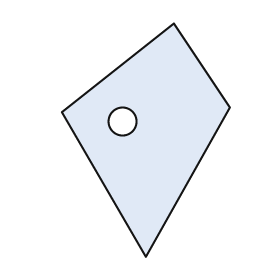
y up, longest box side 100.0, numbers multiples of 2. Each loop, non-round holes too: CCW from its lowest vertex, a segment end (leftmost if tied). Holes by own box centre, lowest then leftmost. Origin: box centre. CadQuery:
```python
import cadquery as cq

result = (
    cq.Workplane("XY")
    .moveTo(0.0, -50.0)
    .lineTo(36.0, 14.0)
    .lineTo(12.0, 50.0)
    .lineTo(-36.0, 12.0)
    .close()
    .moveTo(-10.0, 8.0)
    .circle(6.0)
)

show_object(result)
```